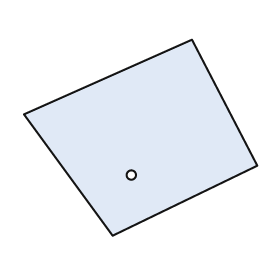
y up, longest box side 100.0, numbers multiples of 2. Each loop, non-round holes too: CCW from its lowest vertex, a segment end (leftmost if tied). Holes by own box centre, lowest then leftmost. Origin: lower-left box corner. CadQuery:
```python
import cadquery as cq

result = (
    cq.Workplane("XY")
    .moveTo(38.0, 0.0)
    .lineTo(100.0, 30.0)
    .lineTo(72.0, 84.0)
    .lineTo(0.0, 52.0)
    .close()
    .moveTo(46.0, 26.0)
    .circle(2.0)
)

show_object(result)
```